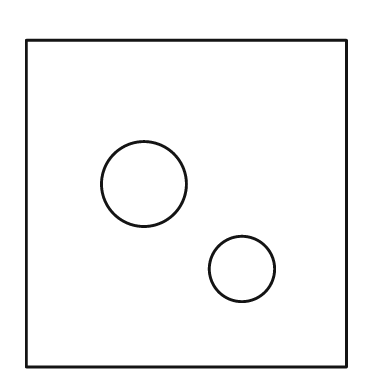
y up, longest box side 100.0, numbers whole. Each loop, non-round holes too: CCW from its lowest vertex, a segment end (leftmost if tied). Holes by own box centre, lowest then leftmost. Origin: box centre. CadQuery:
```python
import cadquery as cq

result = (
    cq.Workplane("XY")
    .moveTo(-49.0, -50.0)
    .lineTo(49.0, -50.0)
    .lineTo(49.0, 50.0)
    .lineTo(-49.0, 50.0)
    .close()
    .moveTo(17.0, -20.0)
    .circle(10.0)
    .moveTo(-13.0, 6.0)
    .circle(13.0)
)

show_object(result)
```